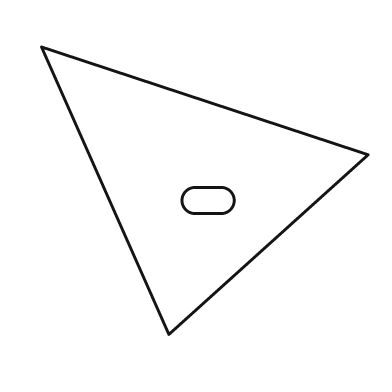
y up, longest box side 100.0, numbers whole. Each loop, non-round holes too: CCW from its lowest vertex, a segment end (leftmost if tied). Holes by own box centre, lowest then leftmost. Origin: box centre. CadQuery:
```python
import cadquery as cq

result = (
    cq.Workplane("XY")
    .moveTo(-11.0, -44.0)
    .lineTo(50.0, 11.0)
    .lineTo(-50.0, 44.0)
    .close()
    .moveTo(-3.0, -7.0)
    .lineTo(5.0, -7.0)
    .threePointArc((9.0, -3.0), (5.0, 1.0))
    .lineTo(-3.0, 1.0)
    .threePointArc((-7.0, -3.0), (-3.0, -7.0))
    .close()
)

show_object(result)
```